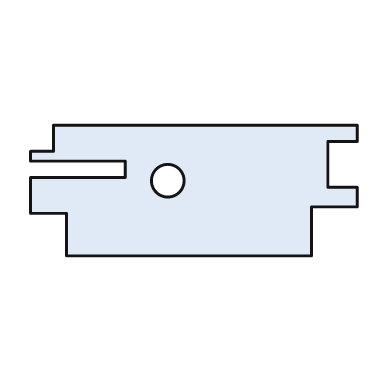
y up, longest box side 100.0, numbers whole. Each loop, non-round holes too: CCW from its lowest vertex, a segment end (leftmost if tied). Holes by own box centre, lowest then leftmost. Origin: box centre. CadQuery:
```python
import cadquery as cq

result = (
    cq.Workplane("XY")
    .moveTo(-39.0, -20.0)
    .lineTo(36.0, -20.0)
    .lineTo(36.0, -5.0)
    .lineTo(50.0, -5.0)
    .lineTo(50.0, 1.0)
    .lineTo(41.0, 1.0)
    .lineTo(41.0, 15.0)
    .lineTo(50.0, 15.0)
    .lineTo(50.0, 20.0)
    .lineTo(-43.0, 20.0)
    .lineTo(-43.0, 12.0)
    .lineTo(-50.0, 12.0)
    .lineTo(-50.0, 9.0)
    .lineTo(-21.0, 9.0)
    .lineTo(-21.0, 4.0)
    .lineTo(-50.0, 4.0)
    .lineTo(-50.0, -7.0)
    .lineTo(-39.0, -7.0)
    .close()
    .moveTo(-8.0, 3.0)
    .circle(5.0)
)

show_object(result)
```